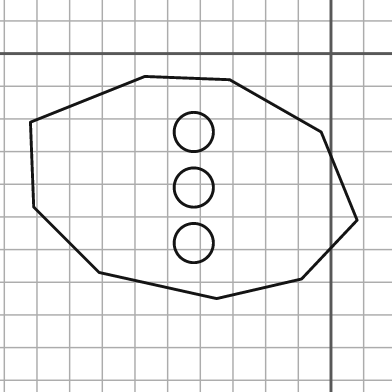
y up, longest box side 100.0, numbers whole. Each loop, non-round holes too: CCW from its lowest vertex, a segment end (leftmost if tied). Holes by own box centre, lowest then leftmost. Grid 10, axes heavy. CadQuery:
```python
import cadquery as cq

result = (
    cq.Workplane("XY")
    .moveTo(-35.0, -75.0)
    .lineTo(-9.0, -69.0)
    .lineTo(8.0, -51.0)
    .lineTo(-3.0, -24.0)
    .lineTo(-31.0, -8.0)
    .lineTo(-57.0, -7.0)
    .lineTo(-92.0, -21.0)
    .lineTo(-91.0, -47.0)
    .lineTo(-71.0, -67.0)
    .close()
    .moveTo(-42.0, -58.0)
    .circle(6.0)
    .moveTo(-42.0, -41.0)
    .circle(6.0)
    .moveTo(-42.0, -24.0)
    .circle(6.0)
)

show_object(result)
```